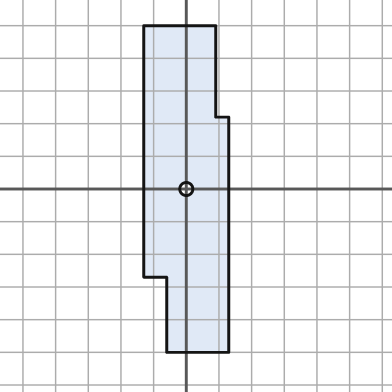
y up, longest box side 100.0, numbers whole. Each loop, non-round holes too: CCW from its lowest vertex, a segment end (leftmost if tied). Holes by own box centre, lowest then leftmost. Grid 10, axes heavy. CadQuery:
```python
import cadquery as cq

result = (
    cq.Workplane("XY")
    .moveTo(-6.0, -50.0)
    .lineTo(13.0, -50.0)
    .lineTo(13.0, 22.0)
    .lineTo(9.0, 22.0)
    .lineTo(9.0, 50.0)
    .lineTo(-13.0, 50.0)
    .lineTo(-13.0, -27.0)
    .lineTo(-6.0, -27.0)
    .close()
    .moveTo(0.0, 0.0)
    .circle(2.0)
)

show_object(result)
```